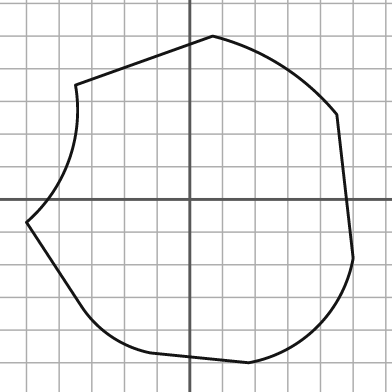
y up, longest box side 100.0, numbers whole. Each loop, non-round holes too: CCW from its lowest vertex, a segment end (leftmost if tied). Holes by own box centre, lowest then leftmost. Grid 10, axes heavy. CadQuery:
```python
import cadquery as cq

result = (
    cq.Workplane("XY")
    .moveTo(18.0, -50.0)
    .threePointArc((39.0, -39.0), (50.0, -18.0))
    .lineTo(45.0, 26.0)
    .threePointArc((28.0, 41.0), (7.0, 50.0))
    .lineTo(-35.0, 35.0)
    .threePointArc((-37.0, 12.0), (-50.0, -7.0))
    .lineTo(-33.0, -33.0)
    .threePointArc((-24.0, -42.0), (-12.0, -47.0))
    .close()
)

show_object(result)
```